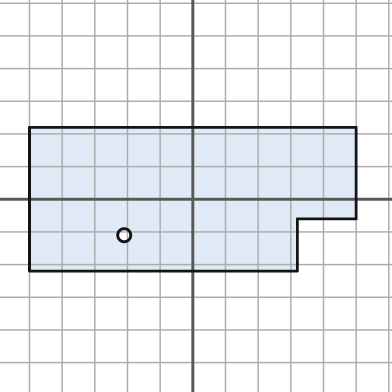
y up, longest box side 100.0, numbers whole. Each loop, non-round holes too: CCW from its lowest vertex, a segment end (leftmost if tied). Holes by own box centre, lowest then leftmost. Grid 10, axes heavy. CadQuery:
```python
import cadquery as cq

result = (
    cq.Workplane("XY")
    .moveTo(-50.0, -22.0)
    .lineTo(32.0, -22.0)
    .lineTo(32.0, -6.0)
    .lineTo(50.0, -6.0)
    .lineTo(50.0, 22.0)
    .lineTo(-50.0, 22.0)
    .close()
    .moveTo(-21.0, -11.0)
    .circle(2.0)
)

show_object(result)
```